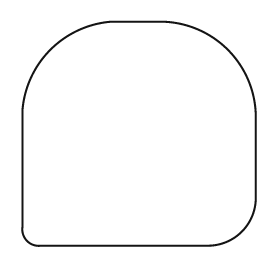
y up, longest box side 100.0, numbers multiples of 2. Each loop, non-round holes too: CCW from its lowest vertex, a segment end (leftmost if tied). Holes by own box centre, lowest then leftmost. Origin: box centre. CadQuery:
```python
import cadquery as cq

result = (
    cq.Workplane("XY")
    .moveTo(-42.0, -48.0)
    .lineTo(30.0, -48.0)
    .threePointArc((44.0, -42.0), (50.0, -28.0))
    .lineTo(50.0, 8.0)
    .threePointArc((38.0, 36.0), (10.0, 48.0))
    .lineTo(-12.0, 48.0)
    .threePointArc((-38.0, 36.0), (-50.0, 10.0))
    .lineTo(-50.0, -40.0)
    .threePointArc((-48.0, -46.0), (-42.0, -48.0))
    .close()
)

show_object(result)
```